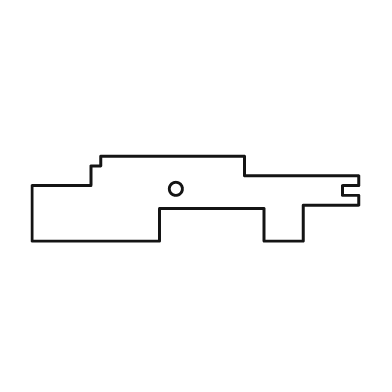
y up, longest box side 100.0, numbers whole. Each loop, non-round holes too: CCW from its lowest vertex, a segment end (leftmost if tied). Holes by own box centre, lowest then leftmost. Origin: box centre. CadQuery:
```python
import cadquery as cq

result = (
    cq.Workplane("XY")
    .moveTo(-50.0, -13.0)
    .lineTo(-11.0, -13.0)
    .lineTo(-11.0, -3.0)
    .lineTo(21.0, -3.0)
    .lineTo(21.0, -13.0)
    .lineTo(33.0, -13.0)
    .lineTo(33.0, -2.0)
    .lineTo(50.0, -2.0)
    .lineTo(50.0, 1.0)
    .lineTo(45.0, 1.0)
    .lineTo(45.0, 4.0)
    .lineTo(50.0, 4.0)
    .lineTo(50.0, 7.0)
    .lineTo(15.0, 7.0)
    .lineTo(15.0, 13.0)
    .lineTo(-29.0, 13.0)
    .lineTo(-29.0, 10.0)
    .lineTo(-32.0, 10.0)
    .lineTo(-32.0, 4.0)
    .lineTo(-50.0, 4.0)
    .close()
    .moveTo(-6.0, 3.0)
    .circle(2.0)
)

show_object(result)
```